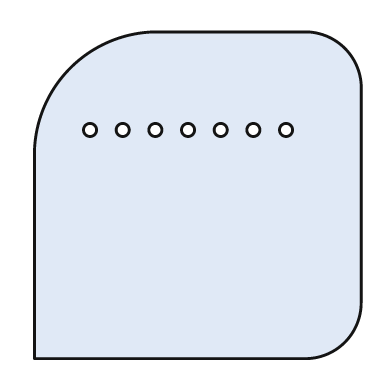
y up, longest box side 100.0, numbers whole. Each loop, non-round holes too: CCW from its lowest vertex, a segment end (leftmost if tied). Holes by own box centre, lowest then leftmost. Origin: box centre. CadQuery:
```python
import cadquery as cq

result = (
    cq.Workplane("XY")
    .moveTo(-50.0, -50.0)
    .lineTo(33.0, -50.0)
    .threePointArc((45.0, -45.0), (50.0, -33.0))
    .lineTo(50.0, 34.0)
    .threePointArc((45.0, 45.0), (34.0, 50.0))
    .lineTo(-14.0, 50.0)
    .threePointArc((-39.0, 39.0), (-50.0, 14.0))
    .close()
    .moveTo(-33.0, 20.0)
    .circle(2.0)
    .moveTo(-23.0, 20.0)
    .circle(2.0)
    .moveTo(-13.0, 20.0)
    .circle(2.0)
    .moveTo(-3.0, 20.0)
    .circle(2.0)
    .moveTo(7.0, 20.0)
    .circle(2.0)
    .moveTo(17.0, 20.0)
    .circle(2.0)
    .moveTo(27.0, 20.0)
    .circle(2.0)
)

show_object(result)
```